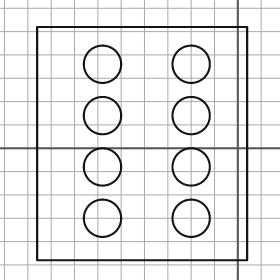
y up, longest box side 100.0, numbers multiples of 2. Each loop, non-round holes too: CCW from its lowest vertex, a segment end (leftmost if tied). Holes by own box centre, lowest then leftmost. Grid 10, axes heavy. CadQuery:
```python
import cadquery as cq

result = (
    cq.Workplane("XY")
    .moveTo(-86.0, -48.0)
    .lineTo(4.0, -48.0)
    .lineTo(4.0, 52.0)
    .lineTo(-86.0, 52.0)
    .close()
    .moveTo(-58.0, -30.0)
    .circle(8.0)
    .moveTo(-20.0, -30.0)
    .circle(8.0)
    .moveTo(-58.0, -8.0)
    .circle(8.0)
    .moveTo(-20.0, -8.0)
    .circle(8.0)
    .moveTo(-58.0, 14.0)
    .circle(8.0)
    .moveTo(-20.0, 14.0)
    .circle(8.0)
    .moveTo(-58.0, 36.0)
    .circle(8.0)
    .moveTo(-20.0, 36.0)
    .circle(8.0)
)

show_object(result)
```